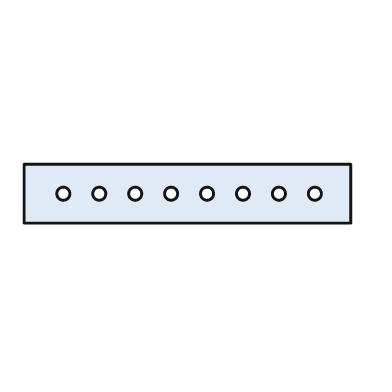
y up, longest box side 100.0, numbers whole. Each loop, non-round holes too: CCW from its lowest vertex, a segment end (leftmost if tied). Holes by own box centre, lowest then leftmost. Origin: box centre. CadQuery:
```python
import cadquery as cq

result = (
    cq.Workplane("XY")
    .moveTo(-50.0, -9.0)
    .lineTo(50.0, -9.0)
    .lineTo(50.0, 9.0)
    .lineTo(-50.0, 9.0)
    .close()
    .moveTo(-38.0, 0.0)
    .circle(2.0)
    .moveTo(-27.0, 0.0)
    .circle(2.0)
    .moveTo(-16.0, 0.0)
    .circle(2.0)
    .moveTo(-5.0, 0.0)
    .circle(2.0)
    .moveTo(6.0, 0.0)
    .circle(2.0)
    .moveTo(17.0, 0.0)
    .circle(2.0)
    .moveTo(28.0, 0.0)
    .circle(2.0)
    .moveTo(39.0, 0.0)
    .circle(2.0)
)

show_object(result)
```